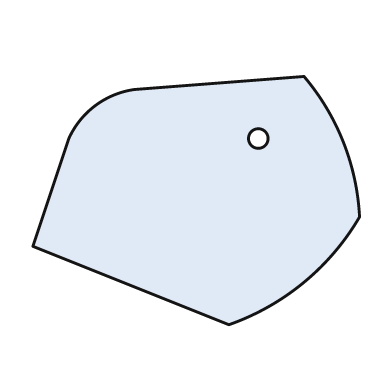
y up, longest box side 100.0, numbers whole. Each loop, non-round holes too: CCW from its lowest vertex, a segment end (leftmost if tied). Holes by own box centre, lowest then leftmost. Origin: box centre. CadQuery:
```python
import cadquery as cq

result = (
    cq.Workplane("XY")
    .moveTo(10.0, -38.0)
    .threePointArc((33.0, -25.0), (50.0, -5.0))
    .threePointArc((45.0, 18.0), (33.0, 38.0))
    .lineTo(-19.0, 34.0)
    .threePointArc((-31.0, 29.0), (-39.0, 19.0))
    .lineTo(-50.0, -14.0)
    .close()
    .moveTo(19.0, 19.0)
    .circle(3.0)
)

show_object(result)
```